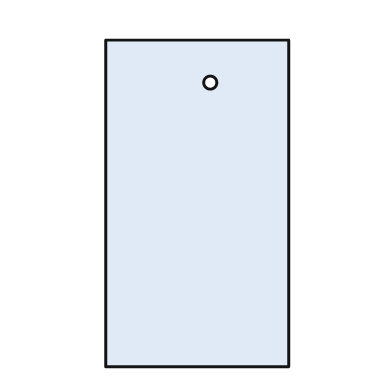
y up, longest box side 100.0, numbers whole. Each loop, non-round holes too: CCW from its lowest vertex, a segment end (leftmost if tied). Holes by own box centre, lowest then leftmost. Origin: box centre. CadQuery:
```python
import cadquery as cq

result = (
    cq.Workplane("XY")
    .moveTo(-28.0, -50.0)
    .lineTo(28.0, -50.0)
    .lineTo(28.0, 50.0)
    .lineTo(-28.0, 50.0)
    .close()
    .moveTo(4.0, 37.0)
    .circle(2.0)
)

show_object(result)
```